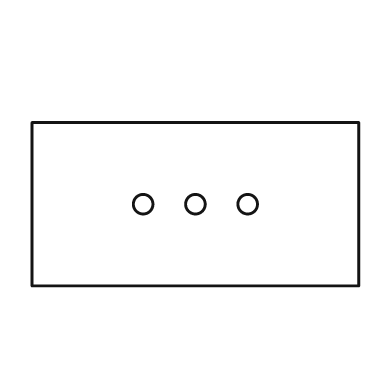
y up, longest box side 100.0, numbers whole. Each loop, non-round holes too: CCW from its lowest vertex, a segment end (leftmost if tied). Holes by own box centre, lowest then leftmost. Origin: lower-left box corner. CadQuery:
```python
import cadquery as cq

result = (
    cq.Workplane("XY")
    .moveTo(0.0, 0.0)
    .lineTo(100.0, 0.0)
    .lineTo(100.0, 50.0)
    .lineTo(0.0, 50.0)
    .close()
    .moveTo(34.0, 25.0)
    .circle(3.0)
    .moveTo(50.0, 25.0)
    .circle(3.0)
    .moveTo(66.0, 25.0)
    .circle(3.0)
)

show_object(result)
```